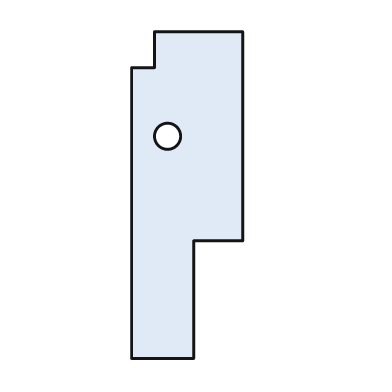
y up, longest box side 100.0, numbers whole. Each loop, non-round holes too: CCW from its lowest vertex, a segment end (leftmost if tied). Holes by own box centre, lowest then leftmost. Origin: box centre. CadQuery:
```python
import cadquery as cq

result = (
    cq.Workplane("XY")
    .moveTo(-17.0, -50.0)
    .lineTo(2.0, -50.0)
    .lineTo(2.0, -14.0)
    .lineTo(17.0, -14.0)
    .lineTo(17.0, 50.0)
    .lineTo(-10.0, 50.0)
    .lineTo(-10.0, 39.0)
    .lineTo(-17.0, 39.0)
    .close()
    .moveTo(-6.0, 18.0)
    .circle(4.0)
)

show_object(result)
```